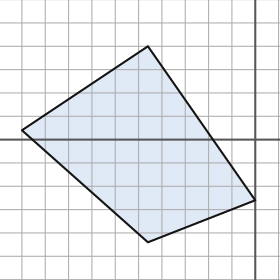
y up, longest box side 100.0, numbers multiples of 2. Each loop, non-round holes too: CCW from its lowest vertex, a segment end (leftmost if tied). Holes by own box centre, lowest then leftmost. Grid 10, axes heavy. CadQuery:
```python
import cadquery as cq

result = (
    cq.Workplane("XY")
    .moveTo(-46.0, -44.0)
    .lineTo(0.0, -26.0)
    .lineTo(-46.0, 40.0)
    .lineTo(-100.0, 4.0)
    .close()
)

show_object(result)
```